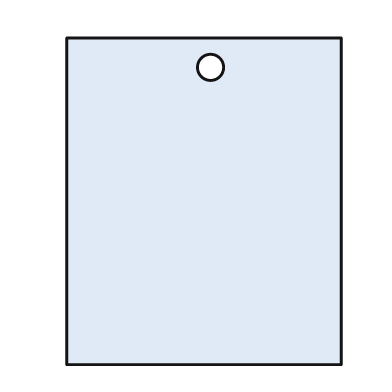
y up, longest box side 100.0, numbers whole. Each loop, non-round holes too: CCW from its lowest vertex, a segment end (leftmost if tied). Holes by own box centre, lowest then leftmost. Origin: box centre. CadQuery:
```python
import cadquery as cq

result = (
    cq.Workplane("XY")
    .moveTo(-42.0, -50.0)
    .lineTo(42.0, -50.0)
    .lineTo(42.0, 50.0)
    .lineTo(-42.0, 50.0)
    .close()
    .moveTo(2.0, 41.0)
    .circle(4.0)
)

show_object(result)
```